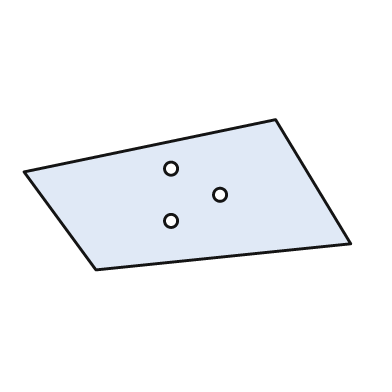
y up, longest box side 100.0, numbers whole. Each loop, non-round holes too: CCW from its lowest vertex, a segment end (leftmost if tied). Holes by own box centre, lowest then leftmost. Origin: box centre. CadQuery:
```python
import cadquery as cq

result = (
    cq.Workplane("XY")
    .moveTo(-28.0, -23.0)
    .lineTo(50.0, -15.0)
    .lineTo(27.0, 23.0)
    .lineTo(-50.0, 7.0)
    .close()
    .moveTo(-5.0, -8.0)
    .circle(2.0)
    .moveTo(10.0, 0.0)
    .circle(2.0)
    .moveTo(-5.0, 8.0)
    .circle(2.0)
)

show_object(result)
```